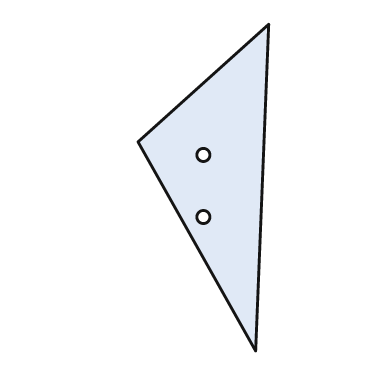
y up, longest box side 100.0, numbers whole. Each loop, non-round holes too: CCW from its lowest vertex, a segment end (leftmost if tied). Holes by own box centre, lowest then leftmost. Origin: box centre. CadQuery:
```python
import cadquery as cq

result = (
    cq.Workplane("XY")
    .moveTo(16.0, -50.0)
    .lineTo(20.0, 50.0)
    .lineTo(-20.0, 14.0)
    .close()
    .moveTo(0.0, -9.0)
    .circle(2.0)
    .moveTo(0.0, 10.0)
    .circle(2.0)
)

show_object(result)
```